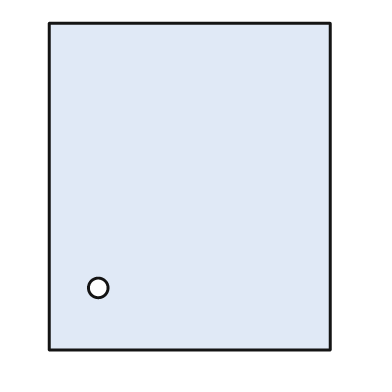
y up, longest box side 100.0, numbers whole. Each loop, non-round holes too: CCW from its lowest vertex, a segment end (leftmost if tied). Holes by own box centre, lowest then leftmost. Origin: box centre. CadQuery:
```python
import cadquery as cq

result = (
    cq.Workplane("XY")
    .moveTo(-43.0, -50.0)
    .lineTo(43.0, -50.0)
    .lineTo(43.0, 50.0)
    .lineTo(-43.0, 50.0)
    .close()
    .moveTo(-28.0, -31.0)
    .circle(3.0)
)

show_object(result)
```